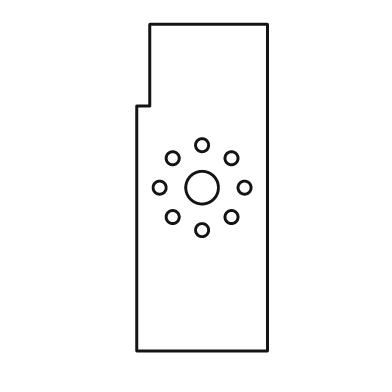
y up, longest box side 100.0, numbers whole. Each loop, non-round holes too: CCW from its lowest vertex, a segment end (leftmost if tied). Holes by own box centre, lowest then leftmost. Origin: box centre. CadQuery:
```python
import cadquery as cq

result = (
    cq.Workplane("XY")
    .moveTo(-20.0, -50.0)
    .lineTo(20.0, -50.0)
    .lineTo(20.0, 50.0)
    .lineTo(-16.0, 50.0)
    .lineTo(-16.0, 25.0)
    .lineTo(-20.0, 25.0)
    .close()
    .moveTo(0.0, -13.0)
    .circle(2.0)
    .moveTo(-9.0, -9.0)
    .circle(2.0)
    .moveTo(9.0, -9.0)
    .circle(2.0)
    .moveTo(-13.0, 0.0)
    .circle(2.0)
    .moveTo(0.0, 0.0)
    .circle(5.0)
    .moveTo(13.0, 0.0)
    .circle(2.0)
    .moveTo(-9.0, 9.0)
    .circle(2.0)
    .moveTo(9.0, 9.0)
    .circle(2.0)
    .moveTo(0.0, 13.0)
    .circle(2.0)
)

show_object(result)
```